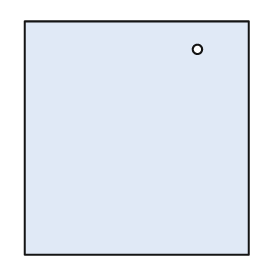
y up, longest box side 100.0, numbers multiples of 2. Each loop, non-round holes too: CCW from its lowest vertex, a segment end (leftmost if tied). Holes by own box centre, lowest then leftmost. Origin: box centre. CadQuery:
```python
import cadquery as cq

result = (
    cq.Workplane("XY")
    .moveTo(-48.0, -50.0)
    .lineTo(48.0, -50.0)
    .lineTo(48.0, 50.0)
    .lineTo(-48.0, 50.0)
    .close()
    .moveTo(26.0, 38.0)
    .circle(2.0)
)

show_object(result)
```